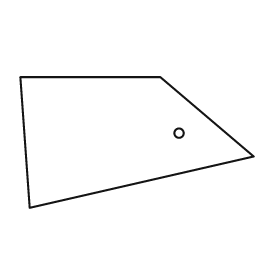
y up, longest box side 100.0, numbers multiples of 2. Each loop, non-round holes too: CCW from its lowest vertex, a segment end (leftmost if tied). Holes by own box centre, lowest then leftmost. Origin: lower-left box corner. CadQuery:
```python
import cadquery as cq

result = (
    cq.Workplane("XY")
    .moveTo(4.0, 0.0)
    .lineTo(100.0, 22.0)
    .lineTo(60.0, 56.0)
    .lineTo(0.0, 56.0)
    .close()
    .moveTo(68.0, 32.0)
    .circle(2.0)
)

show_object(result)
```